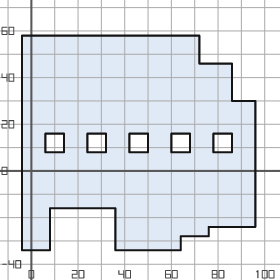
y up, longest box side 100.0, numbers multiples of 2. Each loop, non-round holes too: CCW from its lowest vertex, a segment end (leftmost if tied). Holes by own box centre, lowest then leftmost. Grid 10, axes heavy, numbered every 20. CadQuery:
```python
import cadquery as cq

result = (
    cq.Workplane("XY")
    .moveTo(-4.0, -34.0)
    .lineTo(8.0, -34.0)
    .lineTo(8.0, -16.0)
    .lineTo(36.0, -16.0)
    .lineTo(36.0, -34.0)
    .lineTo(64.0, -34.0)
    .lineTo(64.0, -28.0)
    .lineTo(76.0, -28.0)
    .lineTo(76.0, -24.0)
    .lineTo(96.0, -24.0)
    .lineTo(96.0, 30.0)
    .lineTo(86.0, 30.0)
    .lineTo(86.0, 46.0)
    .lineTo(72.0, 46.0)
    .lineTo(72.0, 58.0)
    .lineTo(-4.0, 58.0)
    .close()
    .moveTo(6.0, 8.0)
    .lineTo(14.0, 8.0)
    .lineTo(14.0, 16.0)
    .lineTo(6.0, 16.0)
    .close()
    .moveTo(24.0, 8.0)
    .lineTo(32.0, 8.0)
    .lineTo(32.0, 16.0)
    .lineTo(24.0, 16.0)
    .close()
    .moveTo(42.0, 8.0)
    .lineTo(50.0, 8.0)
    .lineTo(50.0, 16.0)
    .lineTo(42.0, 16.0)
    .close()
    .moveTo(60.0, 8.0)
    .lineTo(68.0, 8.0)
    .lineTo(68.0, 16.0)
    .lineTo(60.0, 16.0)
    .close()
    .moveTo(78.0, 8.0)
    .lineTo(86.0, 8.0)
    .lineTo(86.0, 16.0)
    .lineTo(78.0, 16.0)
    .close()
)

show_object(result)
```